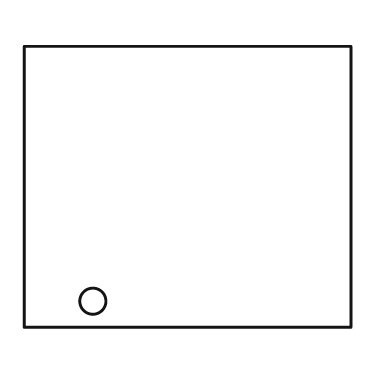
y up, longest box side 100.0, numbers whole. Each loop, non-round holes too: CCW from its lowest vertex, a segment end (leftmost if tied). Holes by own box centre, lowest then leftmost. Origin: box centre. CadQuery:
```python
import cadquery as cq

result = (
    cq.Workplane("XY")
    .moveTo(-50.0, -43.0)
    .lineTo(50.0, -43.0)
    .lineTo(50.0, 43.0)
    .lineTo(-50.0, 43.0)
    .close()
    .moveTo(-29.0, -35.0)
    .circle(4.0)
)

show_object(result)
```